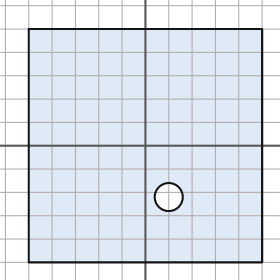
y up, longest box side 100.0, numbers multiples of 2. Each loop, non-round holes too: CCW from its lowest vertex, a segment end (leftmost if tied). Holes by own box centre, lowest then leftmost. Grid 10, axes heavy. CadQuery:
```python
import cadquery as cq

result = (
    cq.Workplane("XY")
    .moveTo(-50.0, -50.0)
    .lineTo(50.0, -50.0)
    .lineTo(50.0, 50.0)
    .lineTo(-50.0, 50.0)
    .close()
    .moveTo(10.0, -22.0)
    .circle(6.0)
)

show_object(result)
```